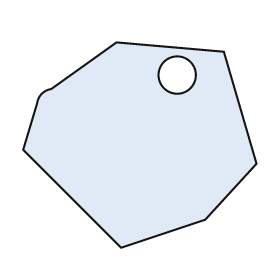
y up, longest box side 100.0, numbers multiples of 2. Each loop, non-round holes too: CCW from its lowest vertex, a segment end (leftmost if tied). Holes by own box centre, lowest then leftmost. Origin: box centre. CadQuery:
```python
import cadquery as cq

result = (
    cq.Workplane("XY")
    .moveTo(-8.0, -44.0)
    .lineTo(28.0, -32.0)
    .lineTo(50.0, -8.0)
    .lineTo(36.0, 40.0)
    .lineTo(-10.0, 44.0)
    .lineTo(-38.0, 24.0)
    .threePointArc((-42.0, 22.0), (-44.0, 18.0))
    .lineTo(-50.0, -2.0)
    .close()
    .moveTo(16.0, 30.0)
    .circle(8.0)
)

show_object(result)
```